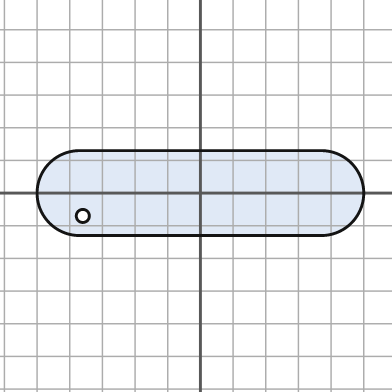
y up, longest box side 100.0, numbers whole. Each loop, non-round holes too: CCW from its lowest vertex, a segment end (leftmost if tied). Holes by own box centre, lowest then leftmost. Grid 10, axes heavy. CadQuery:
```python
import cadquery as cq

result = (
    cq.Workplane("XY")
    .moveTo(-37.0, -13.0)
    .lineTo(37.0, -13.0)
    .threePointArc((50.0, 0.0), (37.0, 13.0))
    .lineTo(-37.0, 13.0)
    .threePointArc((-50.0, 0.0), (-37.0, -13.0))
    .close()
    .moveTo(-36.0, -7.0)
    .circle(2.0)
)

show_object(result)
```